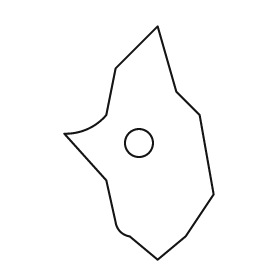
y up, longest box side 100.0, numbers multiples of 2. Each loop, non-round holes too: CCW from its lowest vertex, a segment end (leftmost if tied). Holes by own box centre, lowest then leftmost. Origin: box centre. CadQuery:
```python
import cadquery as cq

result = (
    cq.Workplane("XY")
    .moveTo(8.0, -50.0)
    .lineTo(20.0, -40.0)
    .lineTo(32.0, -22.0)
    .lineTo(26.0, 12.0)
    .lineTo(16.0, 22.0)
    .lineTo(8.0, 50.0)
    .lineTo(-10.0, 32.0)
    .lineTo(-14.0, 12.0)
    .threePointArc((-22.0, 6.0), (-32.0, 4.0))
    .lineTo(-14.0, -16.0)
    .lineTo(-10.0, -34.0)
    .threePointArc((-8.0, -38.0), (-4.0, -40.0))
    .close()
    .moveTo(0.0, 0.0)
    .circle(6.0)
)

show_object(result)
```